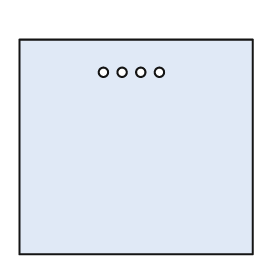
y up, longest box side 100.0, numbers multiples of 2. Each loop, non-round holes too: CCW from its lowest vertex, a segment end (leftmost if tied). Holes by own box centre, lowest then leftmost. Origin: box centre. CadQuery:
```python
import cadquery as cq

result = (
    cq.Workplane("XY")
    .moveTo(-50.0, -46.0)
    .lineTo(50.0, -46.0)
    .lineTo(50.0, 46.0)
    .lineTo(-50.0, 46.0)
    .close()
    .moveTo(-14.0, 32.0)
    .circle(2.0)
    .moveTo(-6.0, 32.0)
    .circle(2.0)
    .moveTo(2.0, 32.0)
    .circle(2.0)
    .moveTo(10.0, 32.0)
    .circle(2.0)
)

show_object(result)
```